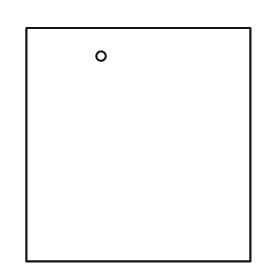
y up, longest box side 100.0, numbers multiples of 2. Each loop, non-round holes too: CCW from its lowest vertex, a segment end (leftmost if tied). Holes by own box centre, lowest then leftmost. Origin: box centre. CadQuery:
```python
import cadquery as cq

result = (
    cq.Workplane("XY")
    .moveTo(-48.0, -50.0)
    .lineTo(48.0, -50.0)
    .lineTo(48.0, 50.0)
    .lineTo(-48.0, 50.0)
    .close()
    .moveTo(-16.0, 38.0)
    .circle(2.0)
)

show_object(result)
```